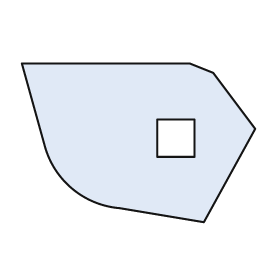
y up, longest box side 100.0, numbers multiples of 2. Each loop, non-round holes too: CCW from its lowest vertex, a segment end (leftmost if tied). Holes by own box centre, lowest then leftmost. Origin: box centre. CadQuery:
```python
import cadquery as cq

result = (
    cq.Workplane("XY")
    .moveTo(28.0, -34.0)
    .lineTo(50.0, 6.0)
    .lineTo(32.0, 30.0)
    .lineTo(22.0, 34.0)
    .lineTo(-50.0, 34.0)
    .lineTo(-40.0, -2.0)
    .threePointArc((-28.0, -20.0), (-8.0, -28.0))
    .close()
    .moveTo(8.0, -6.0)
    .lineTo(24.0, -6.0)
    .lineTo(24.0, 10.0)
    .lineTo(8.0, 10.0)
    .close()
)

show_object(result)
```